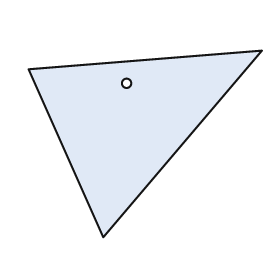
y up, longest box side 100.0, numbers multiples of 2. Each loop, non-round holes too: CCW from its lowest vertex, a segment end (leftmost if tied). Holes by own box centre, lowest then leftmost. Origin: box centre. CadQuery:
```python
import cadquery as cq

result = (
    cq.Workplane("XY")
    .moveTo(-18.0, -40.0)
    .lineTo(50.0, 40.0)
    .lineTo(-50.0, 32.0)
    .close()
    .moveTo(-8.0, 26.0)
    .circle(2.0)
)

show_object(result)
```